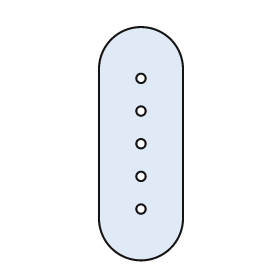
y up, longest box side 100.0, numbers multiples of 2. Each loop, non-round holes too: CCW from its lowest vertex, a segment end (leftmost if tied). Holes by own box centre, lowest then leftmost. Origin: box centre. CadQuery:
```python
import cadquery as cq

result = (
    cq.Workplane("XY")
    .moveTo(-18.0, -32.0)
    .threePointArc((0.0, -50.0), (18.0, -32.0))
    .lineTo(18.0, 32.0)
    .threePointArc((0.0, 50.0), (-18.0, 32.0))
    .close()
    .moveTo(0.0, -28.0)
    .circle(2.0)
    .moveTo(0.0, -14.0)
    .circle(2.0)
    .moveTo(0.0, 0.0)
    .circle(2.0)
    .moveTo(0.0, 14.0)
    .circle(2.0)
    .moveTo(0.0, 28.0)
    .circle(2.0)
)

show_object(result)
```